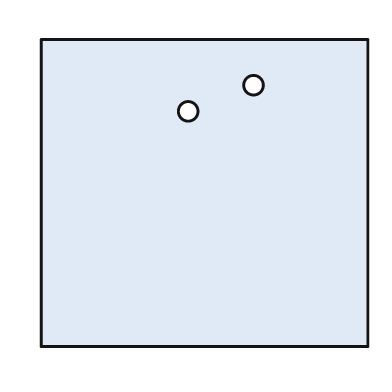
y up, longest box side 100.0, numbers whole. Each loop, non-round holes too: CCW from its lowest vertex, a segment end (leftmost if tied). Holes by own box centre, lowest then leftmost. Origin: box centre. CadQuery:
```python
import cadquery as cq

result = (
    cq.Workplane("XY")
    .moveTo(-50.0, -47.0)
    .lineTo(50.0, -47.0)
    .lineTo(50.0, 47.0)
    .lineTo(-50.0, 47.0)
    .close()
    .moveTo(-5.0, 25.0)
    .circle(3.0)
    .moveTo(15.0, 33.0)
    .circle(3.0)
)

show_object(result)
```